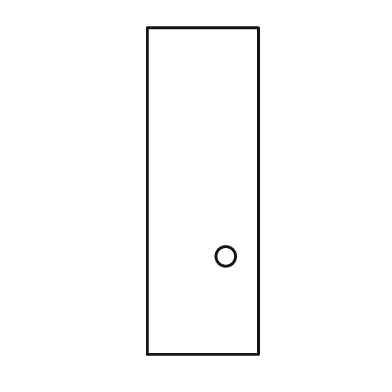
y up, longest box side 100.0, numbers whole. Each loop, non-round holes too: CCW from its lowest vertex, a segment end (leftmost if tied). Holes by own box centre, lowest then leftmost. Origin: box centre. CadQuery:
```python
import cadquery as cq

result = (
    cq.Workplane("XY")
    .moveTo(-17.0, -50.0)
    .lineTo(17.0, -50.0)
    .lineTo(17.0, 50.0)
    .lineTo(-17.0, 50.0)
    .close()
    .moveTo(7.0, -20.0)
    .circle(3.0)
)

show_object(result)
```